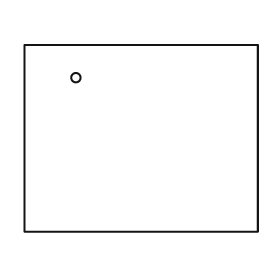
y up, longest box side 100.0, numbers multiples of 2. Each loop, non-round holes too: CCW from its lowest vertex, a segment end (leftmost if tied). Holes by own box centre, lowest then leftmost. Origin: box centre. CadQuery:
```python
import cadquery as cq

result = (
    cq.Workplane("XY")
    .moveTo(-50.0, -40.0)
    .lineTo(50.0, -40.0)
    .lineTo(50.0, 40.0)
    .lineTo(-50.0, 40.0)
    .close()
    .moveTo(-28.0, 26.0)
    .circle(2.0)
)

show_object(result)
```